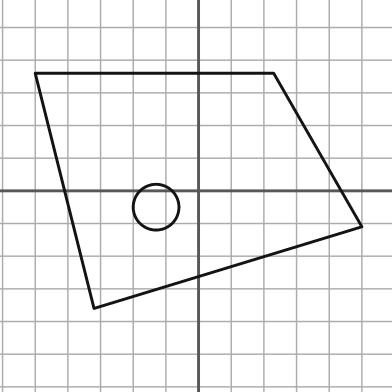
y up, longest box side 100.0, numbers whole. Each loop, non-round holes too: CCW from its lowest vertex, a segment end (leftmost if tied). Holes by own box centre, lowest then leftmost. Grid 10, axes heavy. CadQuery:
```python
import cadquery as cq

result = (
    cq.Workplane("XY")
    .moveTo(-32.0, -36.0)
    .lineTo(50.0, -11.0)
    .lineTo(23.0, 36.0)
    .lineTo(-50.0, 36.0)
    .close()
    .moveTo(-13.0, -5.0)
    .circle(7.0)
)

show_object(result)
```